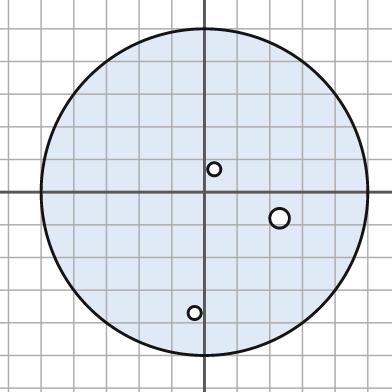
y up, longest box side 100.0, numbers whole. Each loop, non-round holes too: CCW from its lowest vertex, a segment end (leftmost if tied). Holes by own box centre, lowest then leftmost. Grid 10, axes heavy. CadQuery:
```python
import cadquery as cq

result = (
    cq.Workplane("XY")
    .moveTo(0.0, 0.0)
    .circle(50.0)
    .moveTo(-3.0, -37.0)
    .circle(2.0)
    .moveTo(23.0, -8.0)
    .circle(3.0)
    .moveTo(3.0, 7.0)
    .circle(2.0)
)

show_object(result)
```